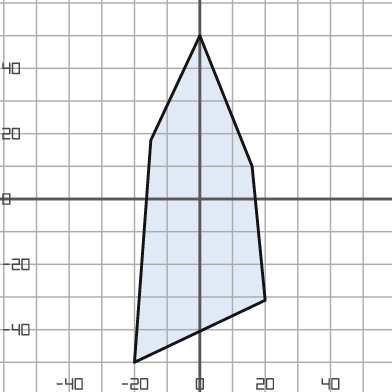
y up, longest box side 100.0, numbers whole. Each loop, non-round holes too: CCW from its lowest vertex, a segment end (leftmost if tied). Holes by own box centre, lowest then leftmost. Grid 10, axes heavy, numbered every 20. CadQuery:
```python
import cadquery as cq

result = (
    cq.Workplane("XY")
    .moveTo(-20.0, -50.0)
    .lineTo(20.0, -31.0)
    .lineTo(16.0, 10.0)
    .lineTo(0.0, 50.0)
    .lineTo(-15.0, 18.0)
    .close()
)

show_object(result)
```